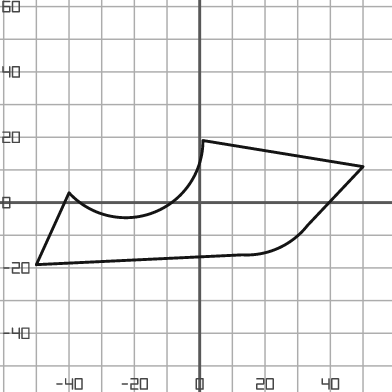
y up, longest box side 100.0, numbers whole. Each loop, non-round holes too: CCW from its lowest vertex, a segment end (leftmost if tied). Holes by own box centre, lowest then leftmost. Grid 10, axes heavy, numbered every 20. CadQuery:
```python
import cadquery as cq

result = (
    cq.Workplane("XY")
    .moveTo(-50.0, -19.0)
    .lineTo(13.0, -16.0)
    .threePointArc((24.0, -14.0), (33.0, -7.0))
    .lineTo(50.0, 11.0)
    .lineTo(1.0, 19.0)
    .threePointArc((-14.0, -3.0), (-40.0, 3.0))
    .close()
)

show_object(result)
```